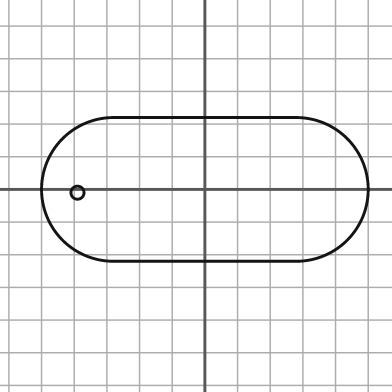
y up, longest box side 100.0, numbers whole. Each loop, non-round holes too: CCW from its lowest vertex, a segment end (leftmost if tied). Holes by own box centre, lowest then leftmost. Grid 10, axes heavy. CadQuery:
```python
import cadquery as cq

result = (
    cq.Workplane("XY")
    .moveTo(-28.0, -22.0)
    .lineTo(28.0, -22.0)
    .threePointArc((50.0, 0.0), (28.0, 22.0))
    .lineTo(-28.0, 22.0)
    .threePointArc((-50.0, 0.0), (-28.0, -22.0))
    .close()
    .moveTo(-39.0, -1.0)
    .circle(2.0)
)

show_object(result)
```